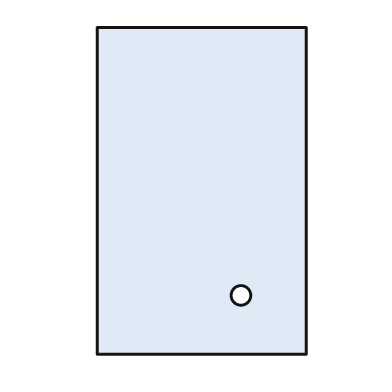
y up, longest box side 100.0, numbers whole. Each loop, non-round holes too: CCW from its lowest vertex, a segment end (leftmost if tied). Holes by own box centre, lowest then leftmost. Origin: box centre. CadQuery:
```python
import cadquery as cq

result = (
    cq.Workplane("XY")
    .moveTo(-32.0, -50.0)
    .lineTo(32.0, -50.0)
    .lineTo(32.0, 50.0)
    .lineTo(-32.0, 50.0)
    .close()
    .moveTo(12.0, -32.0)
    .circle(3.0)
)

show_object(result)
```